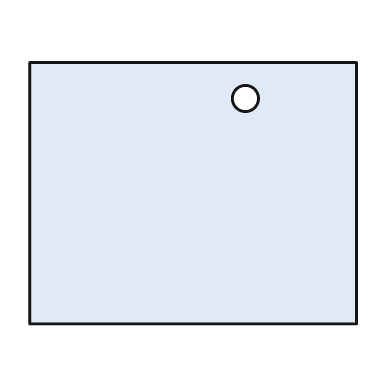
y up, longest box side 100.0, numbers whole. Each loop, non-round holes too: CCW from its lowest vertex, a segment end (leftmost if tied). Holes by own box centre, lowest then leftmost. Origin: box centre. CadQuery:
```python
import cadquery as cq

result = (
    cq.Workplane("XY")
    .moveTo(-50.0, -40.0)
    .lineTo(50.0, -40.0)
    .lineTo(50.0, 40.0)
    .lineTo(-50.0, 40.0)
    .close()
    .moveTo(16.0, 29.0)
    .circle(4.0)
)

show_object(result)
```